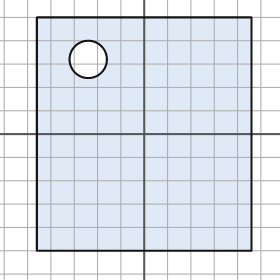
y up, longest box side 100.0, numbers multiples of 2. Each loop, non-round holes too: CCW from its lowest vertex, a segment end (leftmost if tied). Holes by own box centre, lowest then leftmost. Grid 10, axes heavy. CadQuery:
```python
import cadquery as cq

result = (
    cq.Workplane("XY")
    .moveTo(-46.0, -50.0)
    .lineTo(46.0, -50.0)
    .lineTo(46.0, 50.0)
    .lineTo(-46.0, 50.0)
    .close()
    .moveTo(-24.0, 32.0)
    .circle(8.0)
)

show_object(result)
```